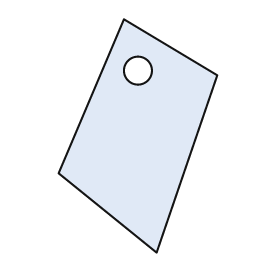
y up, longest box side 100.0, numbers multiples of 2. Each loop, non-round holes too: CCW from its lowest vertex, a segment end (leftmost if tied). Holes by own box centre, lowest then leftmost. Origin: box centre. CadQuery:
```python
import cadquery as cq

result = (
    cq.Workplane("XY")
    .moveTo(8.0, -50.0)
    .lineTo(34.0, 26.0)
    .lineTo(-6.0, 50.0)
    .lineTo(-34.0, -16.0)
    .close()
    .moveTo(0.0, 28.0)
    .circle(6.0)
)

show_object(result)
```